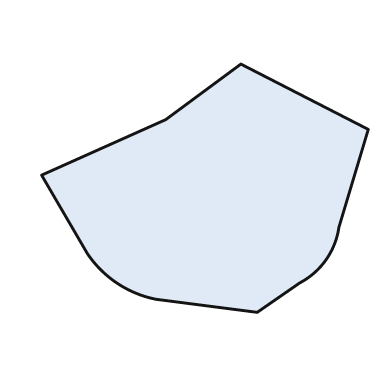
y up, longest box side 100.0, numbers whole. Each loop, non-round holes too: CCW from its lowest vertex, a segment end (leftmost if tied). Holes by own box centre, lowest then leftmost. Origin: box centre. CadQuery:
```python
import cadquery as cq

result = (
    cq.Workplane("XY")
    .moveTo(16.0, -38.0)
    .lineTo(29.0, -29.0)
    .threePointArc((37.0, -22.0), (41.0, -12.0))
    .lineTo(50.0, 18.0)
    .lineTo(11.0, 38.0)
    .lineTo(-12.0, 21.0)
    .lineTo(-50.0, 4.0)
    .lineTo(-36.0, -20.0)
    .threePointArc((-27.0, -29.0), (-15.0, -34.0))
    .close()
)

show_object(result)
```